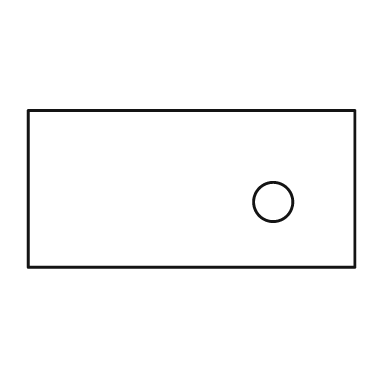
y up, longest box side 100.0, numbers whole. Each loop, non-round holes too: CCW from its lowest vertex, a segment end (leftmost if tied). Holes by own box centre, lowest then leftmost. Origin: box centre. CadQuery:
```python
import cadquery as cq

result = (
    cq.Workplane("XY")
    .moveTo(-50.0, -24.0)
    .lineTo(50.0, -24.0)
    .lineTo(50.0, 24.0)
    .lineTo(-50.0, 24.0)
    .close()
    .moveTo(25.0, -4.0)
    .circle(6.0)
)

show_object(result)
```